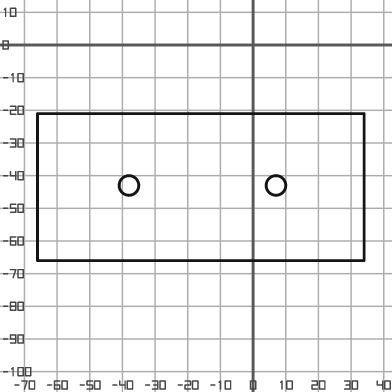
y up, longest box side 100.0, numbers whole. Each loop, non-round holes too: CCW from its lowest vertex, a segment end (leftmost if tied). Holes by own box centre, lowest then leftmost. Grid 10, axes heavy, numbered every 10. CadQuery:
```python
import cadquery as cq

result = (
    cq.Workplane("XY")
    .moveTo(-66.0, -66.0)
    .lineTo(34.0, -66.0)
    .lineTo(34.0, -21.0)
    .lineTo(-66.0, -21.0)
    .close()
    .moveTo(-38.0, -43.0)
    .circle(3.0)
    .moveTo(7.0, -43.0)
    .circle(3.0)
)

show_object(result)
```